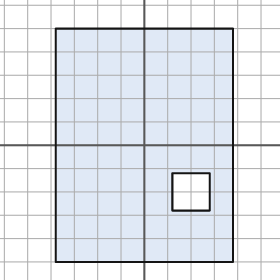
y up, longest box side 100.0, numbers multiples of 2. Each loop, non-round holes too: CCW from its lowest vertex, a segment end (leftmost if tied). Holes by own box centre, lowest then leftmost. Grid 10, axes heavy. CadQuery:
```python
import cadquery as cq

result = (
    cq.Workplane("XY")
    .moveTo(-38.0, -50.0)
    .lineTo(38.0, -50.0)
    .lineTo(38.0, 50.0)
    .lineTo(-38.0, 50.0)
    .close()
    .moveTo(12.0, -28.0)
    .lineTo(28.0, -28.0)
    .lineTo(28.0, -12.0)
    .lineTo(12.0, -12.0)
    .close()
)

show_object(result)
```